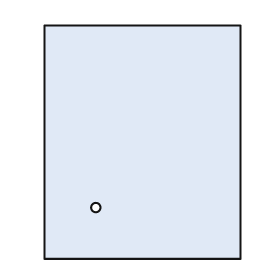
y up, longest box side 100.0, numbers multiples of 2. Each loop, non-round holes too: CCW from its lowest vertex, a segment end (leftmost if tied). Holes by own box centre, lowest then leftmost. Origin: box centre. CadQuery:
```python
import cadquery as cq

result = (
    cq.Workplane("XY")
    .moveTo(-42.0, -50.0)
    .lineTo(42.0, -50.0)
    .lineTo(42.0, 50.0)
    .lineTo(-42.0, 50.0)
    .close()
    .moveTo(-20.0, -28.0)
    .circle(2.0)
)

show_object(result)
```